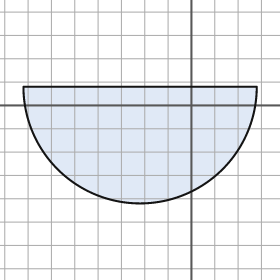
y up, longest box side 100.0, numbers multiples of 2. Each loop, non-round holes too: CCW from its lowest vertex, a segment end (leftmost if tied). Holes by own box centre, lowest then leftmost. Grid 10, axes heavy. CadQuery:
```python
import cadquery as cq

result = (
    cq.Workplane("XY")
    .moveTo(-72.0, 8.0)
    .threePointArc((-22.0, -42.0), (28.0, 8.0))
    .close()
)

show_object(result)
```